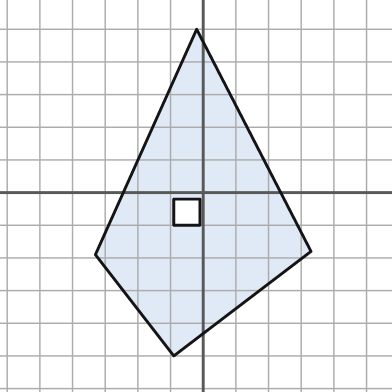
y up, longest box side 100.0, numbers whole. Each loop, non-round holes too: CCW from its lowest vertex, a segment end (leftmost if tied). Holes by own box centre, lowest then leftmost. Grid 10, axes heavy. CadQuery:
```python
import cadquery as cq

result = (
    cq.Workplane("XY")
    .moveTo(-9.0, -50.0)
    .lineTo(33.0, -18.0)
    .lineTo(-2.0, 50.0)
    .lineTo(-33.0, -19.0)
    .close()
    .moveTo(-9.0, -10.0)
    .lineTo(-1.0, -10.0)
    .lineTo(-1.0, -2.0)
    .lineTo(-9.0, -2.0)
    .close()
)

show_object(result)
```